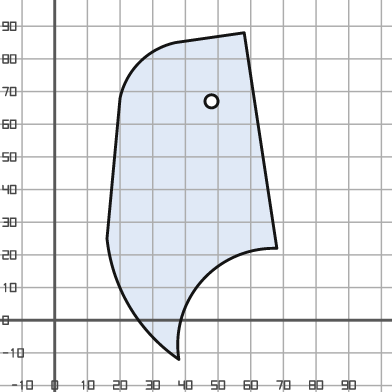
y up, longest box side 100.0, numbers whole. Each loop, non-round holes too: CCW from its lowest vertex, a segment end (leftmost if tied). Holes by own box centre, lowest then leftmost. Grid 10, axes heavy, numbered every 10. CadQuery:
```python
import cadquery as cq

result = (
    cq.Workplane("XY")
    .moveTo(38.0, -12.0)
    .threePointArc((45.0, 12.0), (68.0, 22.0))
    .lineTo(58.0, 88.0)
    .lineTo(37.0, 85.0)
    .threePointArc((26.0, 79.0), (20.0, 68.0))
    .lineTo(16.0, 25.0)
    .threePointArc((23.0, 4.0), (38.0, -12.0))
    .close()
    .moveTo(48.0, 67.0)
    .circle(2.0)
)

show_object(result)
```